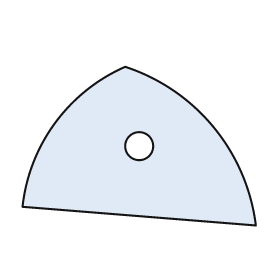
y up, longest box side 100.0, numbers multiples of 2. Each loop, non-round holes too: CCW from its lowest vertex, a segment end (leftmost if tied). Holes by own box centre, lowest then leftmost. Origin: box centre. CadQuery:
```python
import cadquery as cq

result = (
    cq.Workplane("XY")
    .moveTo(50.0, -34.0)
    .threePointArc((32.0, 8.0), (-6.0, 34.0))
    .threePointArc((-36.0, 10.0), (-50.0, -26.0))
    .close()
    .moveTo(0.0, 0.0)
    .circle(6.0)
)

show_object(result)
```